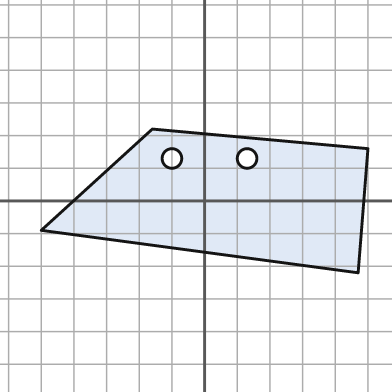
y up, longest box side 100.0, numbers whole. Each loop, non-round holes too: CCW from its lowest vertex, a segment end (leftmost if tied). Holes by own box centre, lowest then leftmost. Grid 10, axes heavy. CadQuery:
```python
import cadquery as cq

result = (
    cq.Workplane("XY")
    .moveTo(47.0, -22.0)
    .lineTo(50.0, 16.0)
    .lineTo(-16.0, 22.0)
    .lineTo(-50.0, -9.0)
    .close()
    .moveTo(-10.0, 13.0)
    .circle(3.0)
    .moveTo(13.0, 13.0)
    .circle(3.0)
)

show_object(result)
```